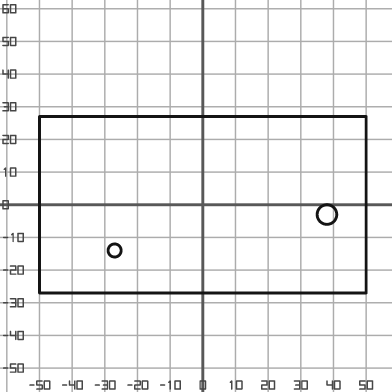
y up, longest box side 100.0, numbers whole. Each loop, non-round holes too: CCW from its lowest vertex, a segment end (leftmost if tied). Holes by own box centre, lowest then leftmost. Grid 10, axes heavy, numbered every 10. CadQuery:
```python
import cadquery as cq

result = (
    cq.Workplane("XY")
    .moveTo(-50.0, -27.0)
    .lineTo(50.0, -27.0)
    .lineTo(50.0, 27.0)
    .lineTo(-50.0, 27.0)
    .close()
    .moveTo(-27.0, -14.0)
    .circle(2.0)
    .moveTo(38.0, -3.0)
    .circle(3.0)
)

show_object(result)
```